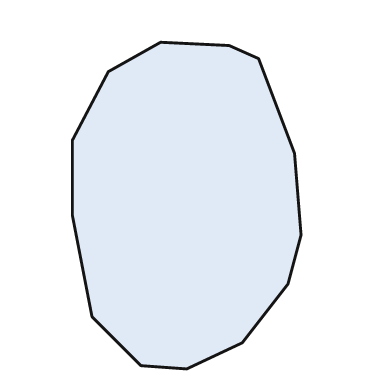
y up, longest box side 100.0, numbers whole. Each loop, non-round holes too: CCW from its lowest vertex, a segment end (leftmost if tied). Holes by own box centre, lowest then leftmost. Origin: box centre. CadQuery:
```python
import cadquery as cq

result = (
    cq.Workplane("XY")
    .moveTo(0.0, -50.0)
    .lineTo(17.0, -42.0)
    .lineTo(31.0, -24.0)
    .lineTo(35.0, -9.0)
    .lineTo(33.0, 16.0)
    .lineTo(22.0, 45.0)
    .lineTo(13.0, 49.0)
    .lineTo(-8.0, 50.0)
    .lineTo(-24.0, 41.0)
    .lineTo(-35.0, 20.0)
    .lineTo(-35.0, -3.0)
    .lineTo(-29.0, -34.0)
    .lineTo(-14.0, -49.0)
    .close()
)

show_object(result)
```